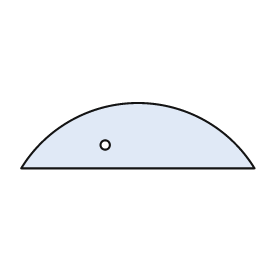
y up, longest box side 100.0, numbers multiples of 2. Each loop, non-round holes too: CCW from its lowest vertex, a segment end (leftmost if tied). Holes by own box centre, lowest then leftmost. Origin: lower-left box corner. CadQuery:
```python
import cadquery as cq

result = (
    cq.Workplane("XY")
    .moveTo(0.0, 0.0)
    .lineTo(100.0, 0.0)
    .threePointArc((50.0, 28.0), (0.0, 0.0))
    .close()
    .moveTo(36.0, 10.0)
    .circle(2.0)
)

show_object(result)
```